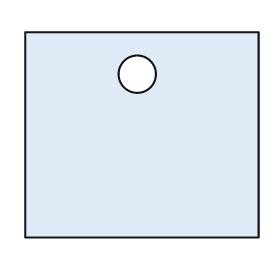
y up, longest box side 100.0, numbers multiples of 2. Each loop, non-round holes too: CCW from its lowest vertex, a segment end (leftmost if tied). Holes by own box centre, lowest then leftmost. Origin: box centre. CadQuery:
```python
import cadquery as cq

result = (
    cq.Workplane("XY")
    .moveTo(-50.0, -44.0)
    .lineTo(50.0, -44.0)
    .lineTo(50.0, 44.0)
    .lineTo(-50.0, 44.0)
    .close()
    .moveTo(-2.0, 26.0)
    .circle(8.0)
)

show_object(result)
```